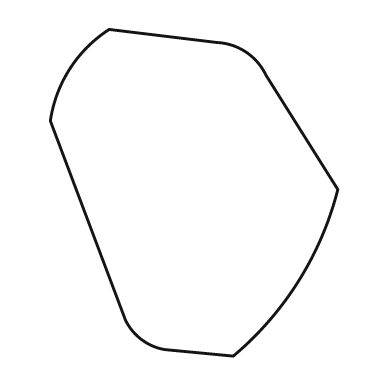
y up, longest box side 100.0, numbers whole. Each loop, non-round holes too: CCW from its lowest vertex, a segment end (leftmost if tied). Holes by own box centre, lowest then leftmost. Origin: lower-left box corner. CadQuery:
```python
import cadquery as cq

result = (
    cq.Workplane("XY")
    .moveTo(56.0, 0.0)
    .threePointArc((76.0, 23.0), (88.0, 51.0))
    .lineTo(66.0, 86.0)
    .threePointArc((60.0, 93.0), (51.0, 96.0))
    .lineTo(18.0, 100.0)
    .threePointArc((6.0, 88.0), (0.0, 72.0))
    .lineTo(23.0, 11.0)
    .threePointArc((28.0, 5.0), (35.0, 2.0))
    .close()
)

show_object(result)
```